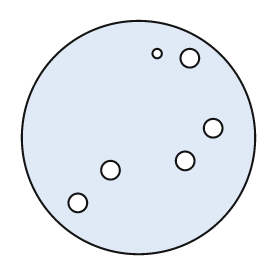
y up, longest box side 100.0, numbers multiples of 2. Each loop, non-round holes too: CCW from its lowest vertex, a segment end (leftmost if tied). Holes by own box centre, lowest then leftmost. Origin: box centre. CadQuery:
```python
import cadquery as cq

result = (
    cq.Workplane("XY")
    .moveTo(0.0, 0.0)
    .circle(50.0)
    .moveTo(-26.0, -28.0)
    .circle(4.0)
    .moveTo(-12.0, -14.0)
    .circle(4.0)
    .moveTo(20.0, -10.0)
    .circle(4.0)
    .moveTo(32.0, 4.0)
    .circle(4.0)
    .moveTo(22.0, 34.0)
    .circle(4.0)
    .moveTo(8.0, 36.0)
    .circle(2.0)
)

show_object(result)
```